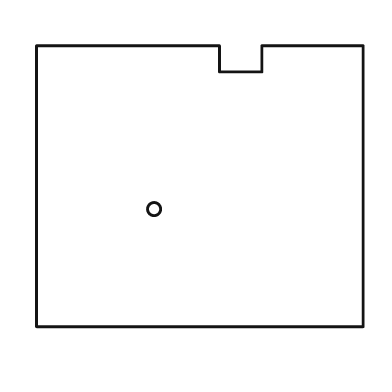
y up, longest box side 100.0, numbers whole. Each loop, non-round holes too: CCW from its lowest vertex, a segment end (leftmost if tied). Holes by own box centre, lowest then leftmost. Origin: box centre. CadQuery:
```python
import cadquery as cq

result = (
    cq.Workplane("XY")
    .moveTo(-50.0, -43.0)
    .lineTo(50.0, -43.0)
    .lineTo(50.0, 43.0)
    .lineTo(19.0, 43.0)
    .lineTo(19.0, 35.0)
    .lineTo(6.0, 35.0)
    .lineTo(6.0, 43.0)
    .lineTo(-50.0, 43.0)
    .close()
    .moveTo(-14.0, -7.0)
    .circle(2.0)
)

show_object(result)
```